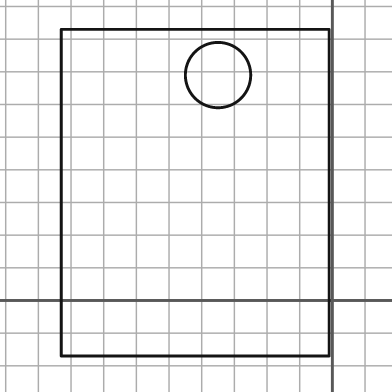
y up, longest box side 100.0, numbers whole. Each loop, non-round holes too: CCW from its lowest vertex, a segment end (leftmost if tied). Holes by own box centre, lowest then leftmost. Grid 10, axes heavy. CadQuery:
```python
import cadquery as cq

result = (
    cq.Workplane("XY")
    .moveTo(-83.0, -17.0)
    .lineTo(-1.0, -17.0)
    .lineTo(-1.0, 83.0)
    .lineTo(-83.0, 83.0)
    .close()
    .moveTo(-35.0, 69.0)
    .circle(10.0)
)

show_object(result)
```